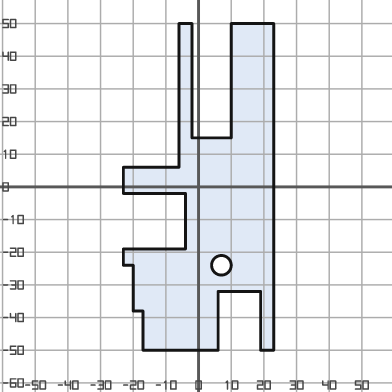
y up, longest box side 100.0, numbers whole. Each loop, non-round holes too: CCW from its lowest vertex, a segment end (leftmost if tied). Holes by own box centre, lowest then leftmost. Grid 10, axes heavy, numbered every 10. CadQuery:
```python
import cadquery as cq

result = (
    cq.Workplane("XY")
    .moveTo(-17.0, -50.0)
    .lineTo(6.0, -50.0)
    .lineTo(6.0, -32.0)
    .lineTo(19.0, -32.0)
    .lineTo(19.0, -50.0)
    .lineTo(23.0, -50.0)
    .lineTo(23.0, 50.0)
    .lineTo(10.0, 50.0)
    .lineTo(10.0, 15.0)
    .lineTo(-2.0, 15.0)
    .lineTo(-2.0, 50.0)
    .lineTo(-6.0, 50.0)
    .lineTo(-6.0, 6.0)
    .lineTo(-23.0, 6.0)
    .lineTo(-23.0, -2.0)
    .lineTo(-4.0, -2.0)
    .lineTo(-4.0, -19.0)
    .lineTo(-23.0, -19.0)
    .lineTo(-23.0, -24.0)
    .lineTo(-20.0, -24.0)
    .lineTo(-20.0, -38.0)
    .lineTo(-17.0, -38.0)
    .close()
    .moveTo(7.0, -24.0)
    .circle(3.0)
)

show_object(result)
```